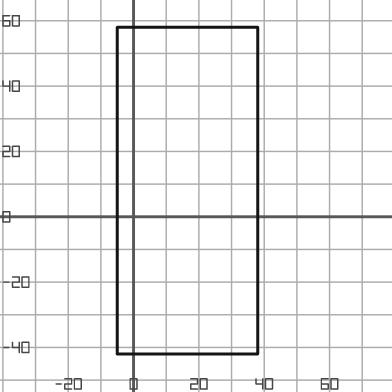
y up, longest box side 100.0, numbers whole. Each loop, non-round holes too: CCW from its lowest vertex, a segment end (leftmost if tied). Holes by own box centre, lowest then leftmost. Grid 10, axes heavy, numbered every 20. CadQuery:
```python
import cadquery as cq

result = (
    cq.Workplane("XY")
    .moveTo(-5.0, -42.0)
    .lineTo(38.0, -42.0)
    .lineTo(38.0, 58.0)
    .lineTo(-5.0, 58.0)
    .close()
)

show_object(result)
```